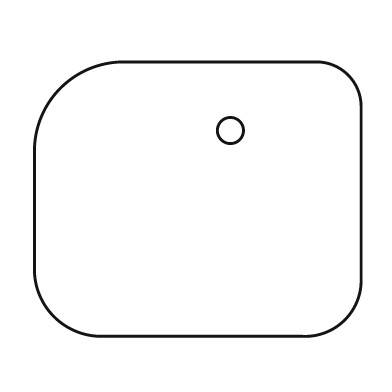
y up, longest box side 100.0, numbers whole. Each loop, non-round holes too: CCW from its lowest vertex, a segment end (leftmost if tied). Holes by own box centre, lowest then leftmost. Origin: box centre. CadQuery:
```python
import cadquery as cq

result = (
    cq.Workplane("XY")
    .moveTo(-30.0, -42.0)
    .lineTo(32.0, -42.0)
    .threePointArc((45.0, -37.0), (50.0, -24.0))
    .lineTo(50.0, 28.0)
    .threePointArc((46.0, 38.0), (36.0, 42.0))
    .lineTo(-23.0, 42.0)
    .threePointArc((-42.0, 34.0), (-50.0, 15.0))
    .lineTo(-50.0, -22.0)
    .threePointArc((-44.0, -36.0), (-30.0, -42.0))
    .close()
    .moveTo(10.0, 21.0)
    .circle(4.0)
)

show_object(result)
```